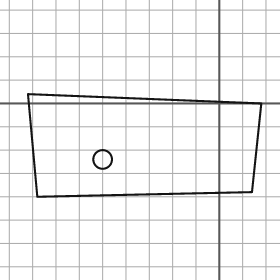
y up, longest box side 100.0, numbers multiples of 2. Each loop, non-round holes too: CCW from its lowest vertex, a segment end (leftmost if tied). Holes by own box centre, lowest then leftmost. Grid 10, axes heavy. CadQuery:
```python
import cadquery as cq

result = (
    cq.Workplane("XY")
    .moveTo(-78.0, -40.0)
    .lineTo(14.0, -38.0)
    .lineTo(18.0, 0.0)
    .lineTo(-82.0, 4.0)
    .close()
    .moveTo(-50.0, -24.0)
    .circle(4.0)
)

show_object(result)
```